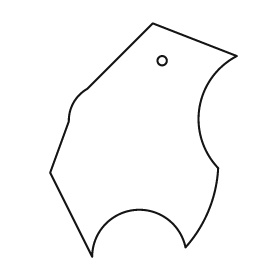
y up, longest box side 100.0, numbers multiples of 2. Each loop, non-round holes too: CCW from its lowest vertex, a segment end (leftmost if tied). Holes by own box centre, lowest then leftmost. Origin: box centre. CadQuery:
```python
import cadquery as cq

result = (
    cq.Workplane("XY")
    .moveTo(-22.0, -50.0)
    .threePointArc((-4.0, -30.0), (18.0, -46.0))
    .threePointArc((28.0, -30.0), (32.0, -12.0))
    .threePointArc((24.0, 14.0), (40.0, 36.0))
    .lineTo(4.0, 50.0)
    .lineTo(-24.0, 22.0)
    .threePointArc((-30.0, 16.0), (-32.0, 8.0))
    .lineTo(-40.0, -14.0)
    .close()
    .moveTo(8.0, 34.0)
    .circle(2.0)
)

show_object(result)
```